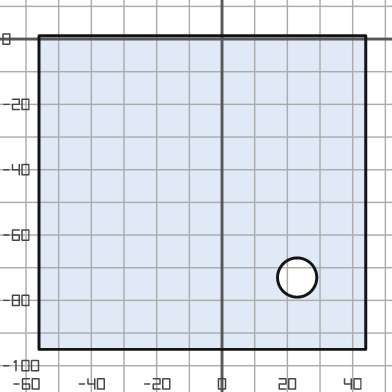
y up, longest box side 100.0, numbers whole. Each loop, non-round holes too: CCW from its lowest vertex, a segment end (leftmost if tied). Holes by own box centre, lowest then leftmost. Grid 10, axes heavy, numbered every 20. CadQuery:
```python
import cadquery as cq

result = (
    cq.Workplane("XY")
    .moveTo(-56.0, -95.0)
    .lineTo(44.0, -95.0)
    .lineTo(44.0, 1.0)
    .lineTo(-56.0, 1.0)
    .close()
    .moveTo(23.0, -73.0)
    .circle(6.0)
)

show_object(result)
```